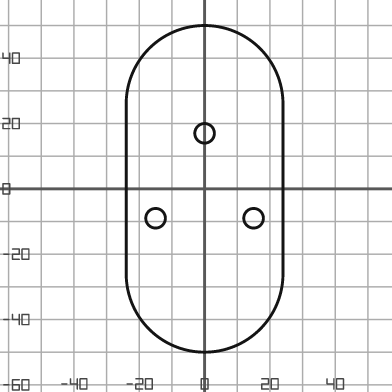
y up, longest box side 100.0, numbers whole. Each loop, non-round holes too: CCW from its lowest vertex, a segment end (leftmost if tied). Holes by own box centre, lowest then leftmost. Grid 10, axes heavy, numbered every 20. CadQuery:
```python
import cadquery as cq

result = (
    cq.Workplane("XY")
    .moveTo(-24.0, -26.0)
    .threePointArc((0.0, -50.0), (24.0, -26.0))
    .lineTo(24.0, 26.0)
    .threePointArc((0.0, 50.0), (-24.0, 26.0))
    .close()
    .moveTo(-15.0, -9.0)
    .circle(3.0)
    .moveTo(15.0, -9.0)
    .circle(3.0)
    .moveTo(0.0, 17.0)
    .circle(3.0)
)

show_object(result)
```